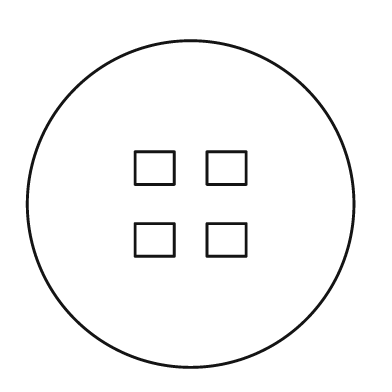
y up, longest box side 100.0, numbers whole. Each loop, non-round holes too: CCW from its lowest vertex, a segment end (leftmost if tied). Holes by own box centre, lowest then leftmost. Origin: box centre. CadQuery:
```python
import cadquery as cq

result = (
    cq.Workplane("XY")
    .moveTo(0.0, 0.0)
    .circle(50.0)
    .moveTo(-17.0, -16.0)
    .lineTo(-5.0, -16.0)
    .lineTo(-5.0, -6.0)
    .lineTo(-17.0, -6.0)
    .close()
    .moveTo(5.0, -16.0)
    .lineTo(17.0, -16.0)
    .lineTo(17.0, -6.0)
    .lineTo(5.0, -6.0)
    .close()
    .moveTo(-17.0, 6.0)
    .lineTo(-5.0, 6.0)
    .lineTo(-5.0, 16.0)
    .lineTo(-17.0, 16.0)
    .close()
    .moveTo(5.0, 6.0)
    .lineTo(17.0, 6.0)
    .lineTo(17.0, 16.0)
    .lineTo(5.0, 16.0)
    .close()
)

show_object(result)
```